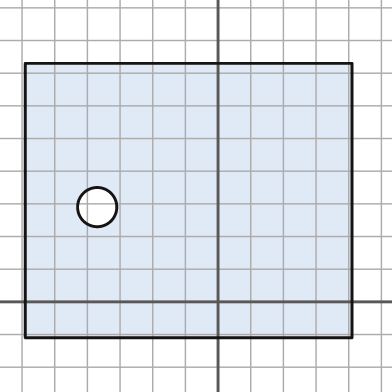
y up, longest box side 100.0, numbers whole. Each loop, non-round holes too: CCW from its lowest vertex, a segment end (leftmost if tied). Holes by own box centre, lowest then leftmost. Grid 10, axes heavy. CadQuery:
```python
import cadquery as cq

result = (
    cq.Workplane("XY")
    .moveTo(-59.0, -11.0)
    .lineTo(41.0, -11.0)
    .lineTo(41.0, 73.0)
    .lineTo(-59.0, 73.0)
    .close()
    .moveTo(-37.0, 29.0)
    .circle(6.0)
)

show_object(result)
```